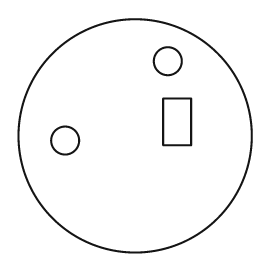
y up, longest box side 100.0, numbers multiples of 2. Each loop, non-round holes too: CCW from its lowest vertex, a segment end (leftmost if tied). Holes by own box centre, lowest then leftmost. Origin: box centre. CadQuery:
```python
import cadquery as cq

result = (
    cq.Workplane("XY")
    .moveTo(0.0, 0.0)
    .circle(50.0)
    .moveTo(-30.0, -2.0)
    .circle(6.0)
    .moveTo(12.0, -4.0)
    .lineTo(24.0, -4.0)
    .lineTo(24.0, 16.0)
    .lineTo(12.0, 16.0)
    .close()
    .moveTo(14.0, 32.0)
    .circle(6.0)
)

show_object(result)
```